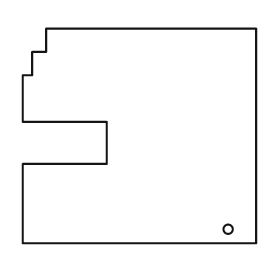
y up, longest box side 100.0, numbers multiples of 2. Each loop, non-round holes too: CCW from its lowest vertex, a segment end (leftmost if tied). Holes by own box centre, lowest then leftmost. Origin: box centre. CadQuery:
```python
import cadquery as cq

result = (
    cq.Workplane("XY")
    .moveTo(-50.0, -46.0)
    .lineTo(50.0, -46.0)
    .lineTo(50.0, 46.0)
    .lineTo(-40.0, 46.0)
    .lineTo(-40.0, 36.0)
    .lineTo(-46.0, 36.0)
    .lineTo(-46.0, 26.0)
    .lineTo(-50.0, 26.0)
    .lineTo(-50.0, 6.0)
    .lineTo(-14.0, 6.0)
    .lineTo(-14.0, -12.0)
    .lineTo(-50.0, -12.0)
    .close()
    .moveTo(38.0, -40.0)
    .circle(2.0)
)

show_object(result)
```